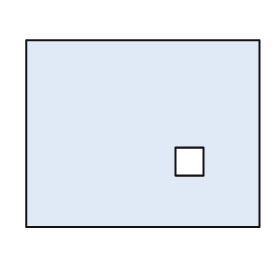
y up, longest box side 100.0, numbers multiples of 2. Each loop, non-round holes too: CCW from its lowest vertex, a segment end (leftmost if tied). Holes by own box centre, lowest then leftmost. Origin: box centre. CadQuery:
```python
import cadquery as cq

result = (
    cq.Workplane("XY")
    .moveTo(-50.0, -40.0)
    .lineTo(50.0, -40.0)
    .lineTo(50.0, 40.0)
    .lineTo(-50.0, 40.0)
    .close()
    .moveTo(14.0, -18.0)
    .lineTo(26.0, -18.0)
    .lineTo(26.0, -6.0)
    .lineTo(14.0, -6.0)
    .close()
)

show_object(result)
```